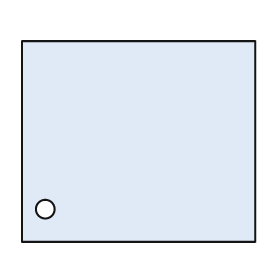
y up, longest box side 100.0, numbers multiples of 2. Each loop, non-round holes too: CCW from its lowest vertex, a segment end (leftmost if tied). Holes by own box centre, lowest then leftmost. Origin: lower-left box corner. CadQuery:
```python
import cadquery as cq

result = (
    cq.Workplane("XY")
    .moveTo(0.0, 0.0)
    .lineTo(100.0, 0.0)
    .lineTo(100.0, 86.0)
    .lineTo(0.0, 86.0)
    .close()
    .moveTo(10.0, 14.0)
    .circle(4.0)
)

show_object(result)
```